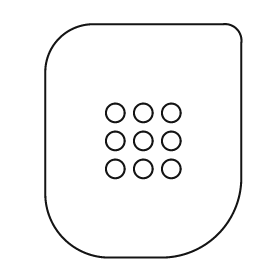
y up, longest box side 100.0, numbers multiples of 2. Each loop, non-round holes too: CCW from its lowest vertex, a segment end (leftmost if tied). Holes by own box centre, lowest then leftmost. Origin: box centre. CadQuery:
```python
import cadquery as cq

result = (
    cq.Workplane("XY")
    .moveTo(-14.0, -50.0)
    .lineTo(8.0, -50.0)
    .threePointArc((32.0, -40.0), (42.0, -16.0))
    .lineTo(42.0, 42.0)
    .threePointArc((40.0, 48.0), (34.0, 50.0))
    .lineTo(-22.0, 50.0)
    .threePointArc((-36.0, 44.0), (-42.0, 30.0))
    .lineTo(-42.0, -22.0)
    .threePointArc((-34.0, -42.0), (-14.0, -50.0))
    .close()
    .moveTo(-12.0, -12.0)
    .circle(4.0)
    .moveTo(0.0, -12.0)
    .circle(4.0)
    .moveTo(12.0, -12.0)
    .circle(4.0)
    .moveTo(-12.0, 0.0)
    .circle(4.0)
    .moveTo(0.0, 0.0)
    .circle(4.0)
    .moveTo(12.0, 0.0)
    .circle(4.0)
    .moveTo(-12.0, 12.0)
    .circle(4.0)
    .moveTo(0.0, 12.0)
    .circle(4.0)
    .moveTo(12.0, 12.0)
    .circle(4.0)
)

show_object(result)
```